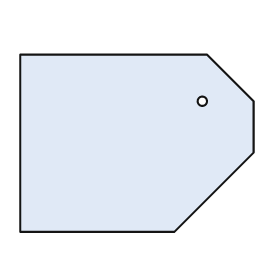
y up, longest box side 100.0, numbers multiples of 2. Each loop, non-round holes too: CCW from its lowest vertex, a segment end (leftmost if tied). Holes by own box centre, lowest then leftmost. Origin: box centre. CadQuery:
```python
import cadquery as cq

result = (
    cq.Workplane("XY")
    .moveTo(-50.0, -38.0)
    .lineTo(16.0, -38.0)
    .lineTo(50.0, -4.0)
    .lineTo(50.0, 18.0)
    .lineTo(30.0, 38.0)
    .lineTo(-50.0, 38.0)
    .close()
    .moveTo(28.0, 18.0)
    .circle(2.0)
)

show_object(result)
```